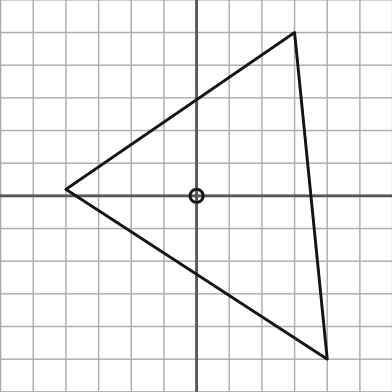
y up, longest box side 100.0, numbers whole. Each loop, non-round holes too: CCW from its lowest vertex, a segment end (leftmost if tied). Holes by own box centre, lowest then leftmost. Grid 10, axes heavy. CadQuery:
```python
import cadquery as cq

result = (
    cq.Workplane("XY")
    .moveTo(40.0, -50.0)
    .lineTo(30.0, 50.0)
    .lineTo(-40.0, 2.0)
    .close()
    .moveTo(0.0, 0.0)
    .circle(2.0)
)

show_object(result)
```